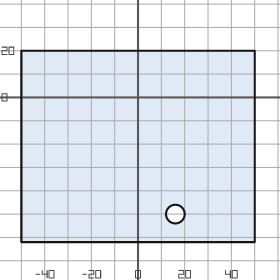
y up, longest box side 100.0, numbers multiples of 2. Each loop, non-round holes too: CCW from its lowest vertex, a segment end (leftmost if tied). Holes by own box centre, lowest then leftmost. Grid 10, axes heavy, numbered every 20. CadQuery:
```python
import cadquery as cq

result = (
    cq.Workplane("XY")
    .moveTo(-50.0, -62.0)
    .lineTo(50.0, -62.0)
    .lineTo(50.0, 20.0)
    .lineTo(-50.0, 20.0)
    .close()
    .moveTo(16.0, -50.0)
    .circle(4.0)
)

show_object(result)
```